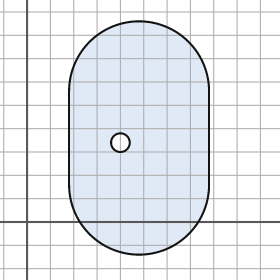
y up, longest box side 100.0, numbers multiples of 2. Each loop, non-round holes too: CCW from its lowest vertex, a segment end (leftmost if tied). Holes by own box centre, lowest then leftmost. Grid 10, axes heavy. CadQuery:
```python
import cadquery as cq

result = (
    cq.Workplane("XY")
    .moveTo(18.0, 16.0)
    .threePointArc((48.0, -14.0), (78.0, 16.0))
    .lineTo(78.0, 56.0)
    .threePointArc((48.0, 86.0), (18.0, 56.0))
    .close()
    .moveTo(40.0, 34.0)
    .circle(4.0)
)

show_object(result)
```